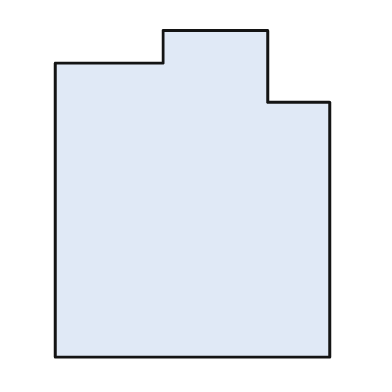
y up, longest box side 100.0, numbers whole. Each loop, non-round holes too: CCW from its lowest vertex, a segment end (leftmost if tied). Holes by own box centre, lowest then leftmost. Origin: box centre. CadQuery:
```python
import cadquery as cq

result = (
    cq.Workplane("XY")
    .moveTo(-42.0, -50.0)
    .lineTo(42.0, -50.0)
    .lineTo(42.0, 28.0)
    .lineTo(23.0, 28.0)
    .lineTo(23.0, 50.0)
    .lineTo(-9.0, 50.0)
    .lineTo(-9.0, 40.0)
    .lineTo(-42.0, 40.0)
    .close()
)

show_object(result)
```